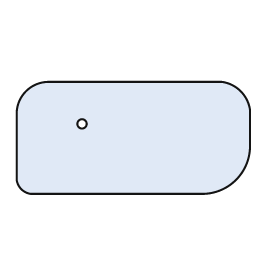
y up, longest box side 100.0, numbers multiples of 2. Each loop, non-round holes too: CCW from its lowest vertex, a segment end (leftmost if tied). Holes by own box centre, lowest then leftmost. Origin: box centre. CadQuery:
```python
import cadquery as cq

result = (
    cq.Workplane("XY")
    .moveTo(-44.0, -24.0)
    .lineTo(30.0, -24.0)
    .threePointArc((44.0, -18.0), (50.0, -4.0))
    .lineTo(50.0, 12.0)
    .threePointArc((46.0, 20.0), (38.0, 24.0))
    .lineTo(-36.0, 24.0)
    .threePointArc((-46.0, 20.0), (-50.0, 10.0))
    .lineTo(-50.0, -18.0)
    .threePointArc((-48.0, -22.0), (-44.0, -24.0))
    .close()
    .moveTo(-22.0, 6.0)
    .circle(2.0)
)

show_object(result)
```